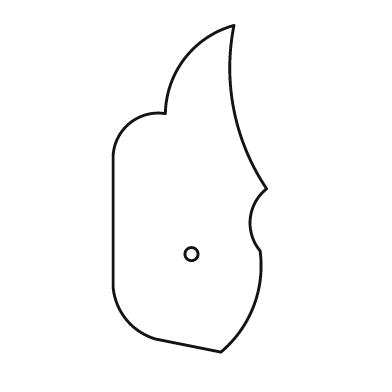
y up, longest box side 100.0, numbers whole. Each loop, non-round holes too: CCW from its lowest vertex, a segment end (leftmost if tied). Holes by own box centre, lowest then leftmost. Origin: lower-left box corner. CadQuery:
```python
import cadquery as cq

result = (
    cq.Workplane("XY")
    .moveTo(33.0, 0.0)
    .threePointArc((43.0, 14.0), (45.0, 31.0))
    .threePointArc((42.0, 41.0), (47.0, 50.0))
    .threePointArc((37.0, 74.0), (37.0, 100.0))
    .threePointArc((22.0, 90.0), (16.0, 73.0))
    .threePointArc((5.0, 70.0), (0.0, 60.0))
    .lineTo(0.0, 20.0)
    .threePointArc((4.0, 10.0), (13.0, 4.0))
    .close()
    .moveTo(24.0, 30.0)
    .circle(2.0)
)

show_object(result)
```